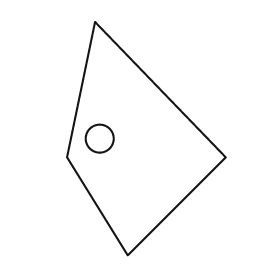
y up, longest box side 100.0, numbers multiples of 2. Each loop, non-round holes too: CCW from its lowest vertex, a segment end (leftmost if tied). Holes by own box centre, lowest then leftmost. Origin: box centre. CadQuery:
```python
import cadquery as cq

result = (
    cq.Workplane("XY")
    .moveTo(-8.0, -50.0)
    .lineTo(34.0, -8.0)
    .lineTo(-22.0, 50.0)
    .lineTo(-34.0, -8.0)
    .close()
    .moveTo(-20.0, 0.0)
    .circle(6.0)
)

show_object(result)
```